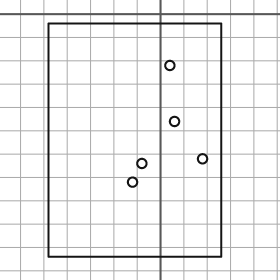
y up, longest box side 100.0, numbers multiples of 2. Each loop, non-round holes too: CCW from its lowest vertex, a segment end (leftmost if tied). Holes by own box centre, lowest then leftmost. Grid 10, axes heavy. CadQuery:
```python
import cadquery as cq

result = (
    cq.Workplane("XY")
    .moveTo(-48.0, -104.0)
    .lineTo(26.0, -104.0)
    .lineTo(26.0, -4.0)
    .lineTo(-48.0, -4.0)
    .close()
    .moveTo(-12.0, -72.0)
    .circle(2.0)
    .moveTo(-8.0, -64.0)
    .circle(2.0)
    .moveTo(18.0, -62.0)
    .circle(2.0)
    .moveTo(6.0, -46.0)
    .circle(2.0)
    .moveTo(4.0, -22.0)
    .circle(2.0)
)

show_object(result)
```